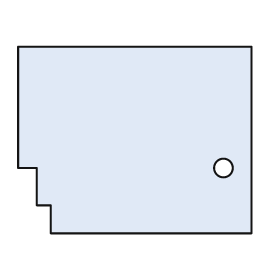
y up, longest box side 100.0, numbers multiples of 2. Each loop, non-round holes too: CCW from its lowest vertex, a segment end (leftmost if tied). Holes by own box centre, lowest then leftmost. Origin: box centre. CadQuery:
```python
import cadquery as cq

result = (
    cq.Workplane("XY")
    .moveTo(-36.0, -40.0)
    .lineTo(50.0, -40.0)
    .lineTo(50.0, 40.0)
    .lineTo(-50.0, 40.0)
    .lineTo(-50.0, -12.0)
    .lineTo(-42.0, -12.0)
    .lineTo(-42.0, -28.0)
    .lineTo(-36.0, -28.0)
    .close()
    .moveTo(38.0, -12.0)
    .circle(4.0)
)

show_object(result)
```